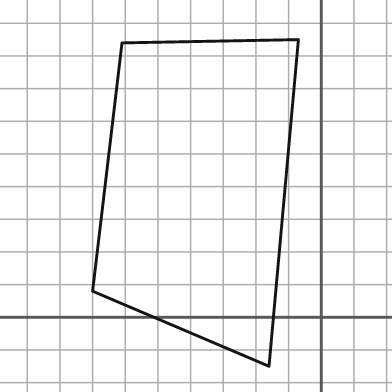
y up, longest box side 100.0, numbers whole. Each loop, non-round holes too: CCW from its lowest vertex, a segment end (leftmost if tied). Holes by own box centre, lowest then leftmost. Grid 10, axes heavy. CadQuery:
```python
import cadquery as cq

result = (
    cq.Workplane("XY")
    .moveTo(-16.0, -15.0)
    .lineTo(-7.0, 85.0)
    .lineTo(-61.0, 84.0)
    .lineTo(-70.0, 8.0)
    .close()
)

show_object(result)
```